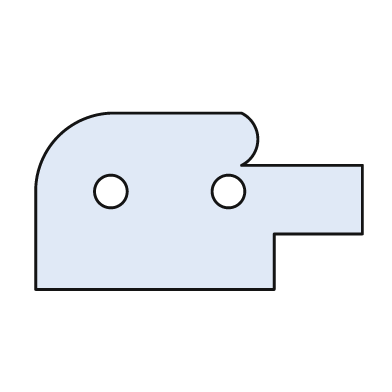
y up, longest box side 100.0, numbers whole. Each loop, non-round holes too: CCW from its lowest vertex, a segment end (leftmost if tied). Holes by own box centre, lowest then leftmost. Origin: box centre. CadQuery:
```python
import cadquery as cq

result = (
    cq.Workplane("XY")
    .moveTo(-50.0, -27.0)
    .lineTo(23.0, -27.0)
    .lineTo(23.0, -10.0)
    .lineTo(50.0, -10.0)
    .lineTo(50.0, 11.0)
    .lineTo(13.0, 11.0)
    .threePointArc((18.0, 19.0), (13.0, 27.0))
    .lineTo(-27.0, 27.0)
    .threePointArc((-43.0, 20.0), (-50.0, 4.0))
    .close()
    .moveTo(-27.0, 3.0)
    .circle(5.0)
    .moveTo(9.0, 3.0)
    .circle(5.0)
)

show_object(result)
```